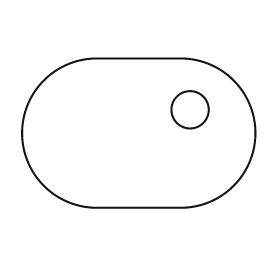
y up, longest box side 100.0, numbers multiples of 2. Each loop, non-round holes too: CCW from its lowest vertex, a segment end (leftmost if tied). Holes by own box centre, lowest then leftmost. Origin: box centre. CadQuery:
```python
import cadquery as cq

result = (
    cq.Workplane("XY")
    .moveTo(-18.0, -32.0)
    .lineTo(18.0, -32.0)
    .threePointArc((50.0, 0.0), (18.0, 32.0))
    .lineTo(-18.0, 32.0)
    .threePointArc((-50.0, 0.0), (-18.0, -32.0))
    .close()
    .moveTo(22.0, 10.0)
    .circle(8.0)
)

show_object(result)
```